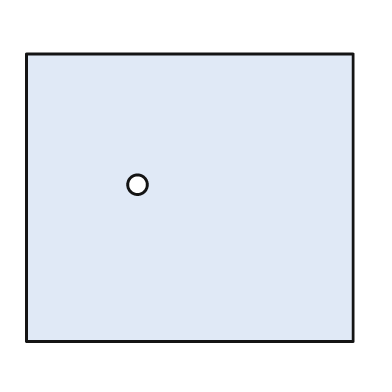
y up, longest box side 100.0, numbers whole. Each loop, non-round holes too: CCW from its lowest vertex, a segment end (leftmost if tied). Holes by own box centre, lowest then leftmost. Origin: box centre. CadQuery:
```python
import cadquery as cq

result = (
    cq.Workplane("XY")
    .moveTo(-50.0, -44.0)
    .lineTo(50.0, -44.0)
    .lineTo(50.0, 44.0)
    .lineTo(-50.0, 44.0)
    .close()
    .moveTo(-16.0, 4.0)
    .circle(3.0)
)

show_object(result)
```